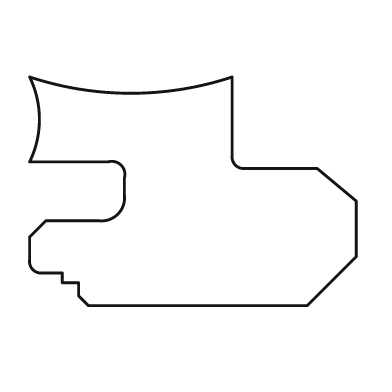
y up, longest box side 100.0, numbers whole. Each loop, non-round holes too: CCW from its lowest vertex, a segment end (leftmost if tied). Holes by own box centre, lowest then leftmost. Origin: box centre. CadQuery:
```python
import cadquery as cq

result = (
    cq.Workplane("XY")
    .moveTo(-32.0, -35.0)
    .lineTo(35.0, -35.0)
    .lineTo(50.0, -20.0)
    .lineTo(50.0, -3.0)
    .lineTo(38.0, 7.0)
    .lineTo(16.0, 7.0)
    .threePointArc((13.0, 8.0), (12.0, 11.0))
    .lineTo(12.0, 35.0)
    .threePointArc((-19.0, 30.0), (-50.0, 35.0))
    .threePointArc((-47.0, 22.0), (-50.0, 9.0))
    .lineTo(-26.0, 9.0)
    .threePointArc((-22.0, 8.0), (-21.0, 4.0))
    .lineTo(-21.0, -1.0)
    .threePointArc((-23.0, -7.0), (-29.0, -9.0))
    .lineTo(-45.0, -9.0)
    .lineTo(-50.0, -14.0)
    .lineTo(-50.0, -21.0)
    .threePointArc((-49.0, -24.0), (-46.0, -25.0))
    .lineTo(-40.0, -25.0)
    .lineTo(-40.0, -28.0)
    .lineTo(-35.0, -28.0)
    .lineTo(-35.0, -32.0)
    .close()
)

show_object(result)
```